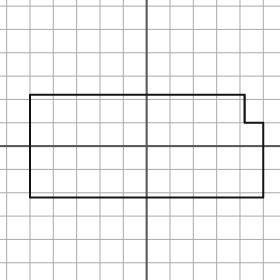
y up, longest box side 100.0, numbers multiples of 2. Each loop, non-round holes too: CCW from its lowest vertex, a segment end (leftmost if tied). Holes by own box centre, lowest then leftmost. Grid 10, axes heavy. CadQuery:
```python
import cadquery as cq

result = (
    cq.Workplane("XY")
    .moveTo(-50.0, -22.0)
    .lineTo(50.0, -22.0)
    .lineTo(50.0, 10.0)
    .lineTo(42.0, 10.0)
    .lineTo(42.0, 22.0)
    .lineTo(-50.0, 22.0)
    .close()
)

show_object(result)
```